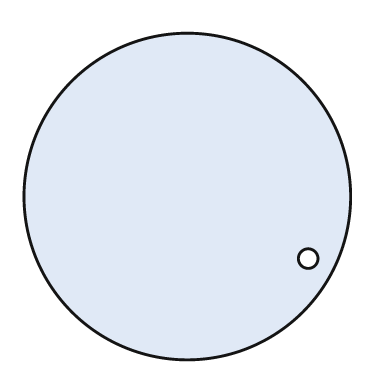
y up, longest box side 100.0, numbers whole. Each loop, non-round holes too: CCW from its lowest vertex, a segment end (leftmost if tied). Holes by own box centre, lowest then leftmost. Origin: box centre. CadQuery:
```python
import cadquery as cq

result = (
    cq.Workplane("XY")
    .moveTo(0.0, 0.0)
    .circle(50.0)
    .moveTo(37.0, -19.0)
    .circle(3.0)
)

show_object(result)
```